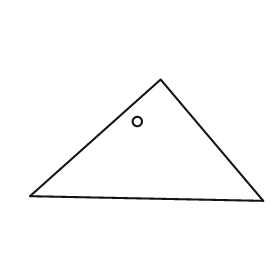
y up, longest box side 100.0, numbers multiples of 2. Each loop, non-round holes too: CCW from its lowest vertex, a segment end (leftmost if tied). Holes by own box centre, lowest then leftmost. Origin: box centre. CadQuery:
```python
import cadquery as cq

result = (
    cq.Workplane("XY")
    .moveTo(50.0, -26.0)
    .lineTo(6.0, 26.0)
    .lineTo(-50.0, -24.0)
    .close()
    .moveTo(-4.0, 8.0)
    .circle(2.0)
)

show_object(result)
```